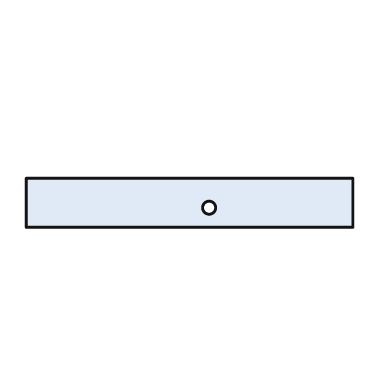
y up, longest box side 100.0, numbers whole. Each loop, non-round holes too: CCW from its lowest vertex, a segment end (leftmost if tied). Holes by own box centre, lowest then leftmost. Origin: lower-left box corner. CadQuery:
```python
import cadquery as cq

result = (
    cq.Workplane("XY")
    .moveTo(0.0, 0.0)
    .lineTo(100.0, 0.0)
    .lineTo(100.0, 15.0)
    .lineTo(0.0, 15.0)
    .close()
    .moveTo(56.0, 6.0)
    .circle(2.0)
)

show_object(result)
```